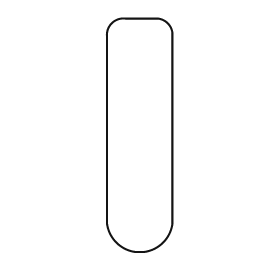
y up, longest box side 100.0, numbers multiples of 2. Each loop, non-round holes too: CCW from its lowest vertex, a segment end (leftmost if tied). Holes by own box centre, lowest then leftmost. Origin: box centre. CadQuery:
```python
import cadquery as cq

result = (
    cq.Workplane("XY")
    .moveTo(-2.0, -50.0)
    .lineTo(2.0, -50.0)
    .threePointArc((10.0, -46.0), (14.0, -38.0))
    .lineTo(14.0, 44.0)
    .threePointArc((12.0, 48.0), (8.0, 50.0))
    .lineTo(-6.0, 50.0)
    .threePointArc((-12.0, 48.0), (-14.0, 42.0))
    .lineTo(-14.0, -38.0)
    .threePointArc((-10.0, -46.0), (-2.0, -50.0))
    .close()
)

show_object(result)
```